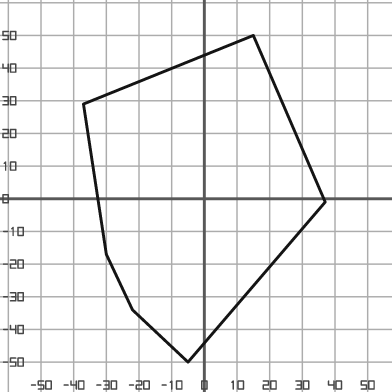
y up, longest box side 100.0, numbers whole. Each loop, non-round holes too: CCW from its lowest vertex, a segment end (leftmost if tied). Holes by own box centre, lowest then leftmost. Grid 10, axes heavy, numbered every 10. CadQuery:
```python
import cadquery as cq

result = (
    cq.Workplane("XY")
    .moveTo(-5.0, -50.0)
    .lineTo(37.0, -1.0)
    .lineTo(15.0, 50.0)
    .lineTo(-37.0, 29.0)
    .lineTo(-30.0, -17.0)
    .lineTo(-22.0, -34.0)
    .close()
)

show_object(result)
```